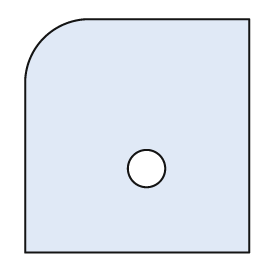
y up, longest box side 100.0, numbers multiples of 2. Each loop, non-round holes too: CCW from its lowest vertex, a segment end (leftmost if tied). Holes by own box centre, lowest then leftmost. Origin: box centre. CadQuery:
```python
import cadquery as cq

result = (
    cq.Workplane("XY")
    .moveTo(-48.0, -50.0)
    .lineTo(48.0, -50.0)
    .lineTo(48.0, 50.0)
    .lineTo(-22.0, 50.0)
    .threePointArc((-40.0, 42.0), (-48.0, 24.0))
    .close()
    .moveTo(4.0, -14.0)
    .circle(8.0)
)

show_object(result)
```